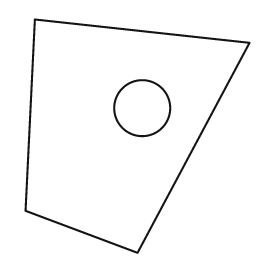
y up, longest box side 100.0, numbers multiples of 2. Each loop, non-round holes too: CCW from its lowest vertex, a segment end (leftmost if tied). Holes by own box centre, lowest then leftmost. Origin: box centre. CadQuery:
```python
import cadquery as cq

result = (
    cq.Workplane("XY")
    .moveTo(0.0, -50.0)
    .lineTo(48.0, 40.0)
    .lineTo(-44.0, 50.0)
    .lineTo(-48.0, -32.0)
    .close()
    .moveTo(2.0, 12.0)
    .circle(12.0)
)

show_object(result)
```